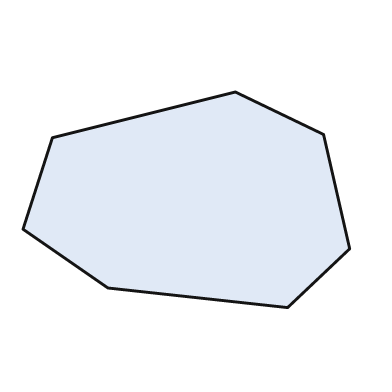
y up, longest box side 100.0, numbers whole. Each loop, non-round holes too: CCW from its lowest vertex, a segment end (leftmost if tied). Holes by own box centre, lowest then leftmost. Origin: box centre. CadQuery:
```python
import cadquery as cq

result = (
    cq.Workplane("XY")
    .moveTo(31.0, -33.0)
    .lineTo(50.0, -15.0)
    .lineTo(42.0, 20.0)
    .lineTo(15.0, 33.0)
    .lineTo(-41.0, 19.0)
    .lineTo(-50.0, -9.0)
    .lineTo(-24.0, -27.0)
    .close()
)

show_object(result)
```